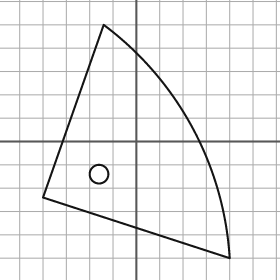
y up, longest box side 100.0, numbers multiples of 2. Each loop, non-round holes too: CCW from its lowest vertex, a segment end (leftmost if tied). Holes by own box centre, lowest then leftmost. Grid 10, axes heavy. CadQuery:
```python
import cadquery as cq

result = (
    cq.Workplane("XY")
    .moveTo(40.0, -50.0)
    .threePointArc((24.0, 6.0), (-14.0, 50.0))
    .lineTo(-40.0, -24.0)
    .close()
    .moveTo(-16.0, -14.0)
    .circle(4.0)
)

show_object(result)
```